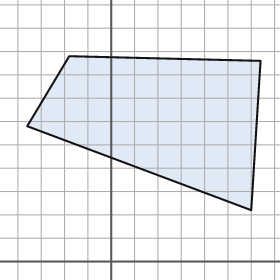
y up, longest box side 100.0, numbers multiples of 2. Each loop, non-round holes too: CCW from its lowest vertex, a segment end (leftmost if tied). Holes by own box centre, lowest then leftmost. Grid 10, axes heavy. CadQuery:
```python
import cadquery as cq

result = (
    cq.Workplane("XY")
    .moveTo(60.0, 22.0)
    .lineTo(64.0, 86.0)
    .lineTo(-18.0, 88.0)
    .lineTo(-36.0, 58.0)
    .close()
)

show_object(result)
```